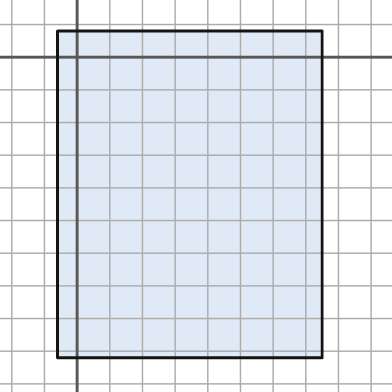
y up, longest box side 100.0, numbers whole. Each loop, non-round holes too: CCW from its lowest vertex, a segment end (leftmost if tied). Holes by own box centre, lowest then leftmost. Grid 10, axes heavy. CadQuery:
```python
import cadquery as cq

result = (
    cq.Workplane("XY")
    .moveTo(-6.0, -92.0)
    .lineTo(75.0, -92.0)
    .lineTo(75.0, 8.0)
    .lineTo(-6.0, 8.0)
    .close()
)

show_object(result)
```